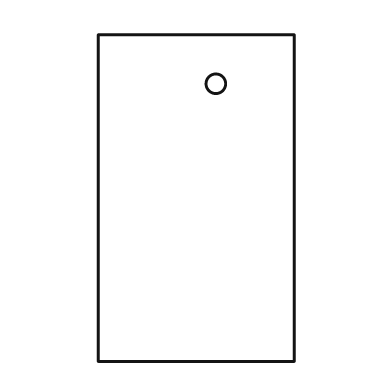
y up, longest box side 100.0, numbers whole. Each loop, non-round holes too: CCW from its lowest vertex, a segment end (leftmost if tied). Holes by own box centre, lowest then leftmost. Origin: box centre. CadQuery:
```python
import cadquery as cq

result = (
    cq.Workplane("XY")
    .moveTo(-30.0, -50.0)
    .lineTo(30.0, -50.0)
    .lineTo(30.0, 50.0)
    .lineTo(-30.0, 50.0)
    .close()
    .moveTo(6.0, 35.0)
    .circle(3.0)
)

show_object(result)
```